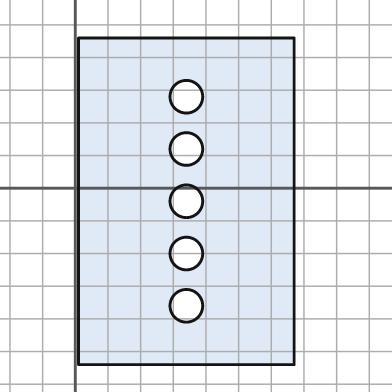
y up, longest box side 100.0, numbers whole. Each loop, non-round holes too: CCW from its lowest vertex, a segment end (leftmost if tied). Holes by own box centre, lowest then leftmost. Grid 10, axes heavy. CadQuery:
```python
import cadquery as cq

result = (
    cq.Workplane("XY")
    .moveTo(1.0, -54.0)
    .lineTo(67.0, -54.0)
    .lineTo(67.0, 46.0)
    .lineTo(1.0, 46.0)
    .close()
    .moveTo(34.0, -36.0)
    .circle(5.0)
    .moveTo(34.0, -20.0)
    .circle(5.0)
    .moveTo(34.0, -4.0)
    .circle(5.0)
    .moveTo(34.0, 12.0)
    .circle(5.0)
    .moveTo(34.0, 28.0)
    .circle(5.0)
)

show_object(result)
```